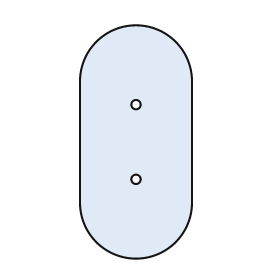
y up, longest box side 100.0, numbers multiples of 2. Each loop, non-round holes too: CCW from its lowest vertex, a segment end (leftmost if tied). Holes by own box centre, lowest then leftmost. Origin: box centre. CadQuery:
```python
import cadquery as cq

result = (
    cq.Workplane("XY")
    .moveTo(-24.0, -26.0)
    .threePointArc((0.0, -50.0), (24.0, -26.0))
    .lineTo(24.0, 26.0)
    .threePointArc((0.0, 50.0), (-24.0, 26.0))
    .close()
    .moveTo(0.0, -16.0)
    .circle(2.0)
    .moveTo(0.0, 16.0)
    .circle(2.0)
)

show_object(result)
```